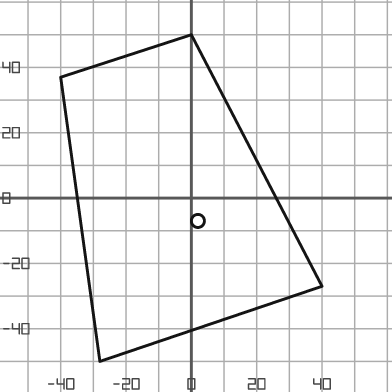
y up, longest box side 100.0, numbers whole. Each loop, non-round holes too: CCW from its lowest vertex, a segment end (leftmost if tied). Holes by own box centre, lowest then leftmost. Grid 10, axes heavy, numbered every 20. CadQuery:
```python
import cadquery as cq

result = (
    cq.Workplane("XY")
    .moveTo(-28.0, -50.0)
    .lineTo(40.0, -27.0)
    .lineTo(0.0, 50.0)
    .lineTo(-40.0, 37.0)
    .close()
    .moveTo(2.0, -7.0)
    .circle(2.0)
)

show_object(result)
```